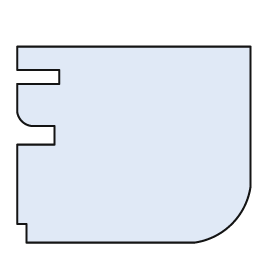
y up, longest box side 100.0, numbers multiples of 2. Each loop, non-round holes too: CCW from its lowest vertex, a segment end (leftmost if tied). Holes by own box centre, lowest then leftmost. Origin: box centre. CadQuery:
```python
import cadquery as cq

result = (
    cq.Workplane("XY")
    .moveTo(-46.0, -42.0)
    .lineTo(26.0, -42.0)
    .threePointArc((42.0, -34.0), (50.0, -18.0))
    .lineTo(50.0, 42.0)
    .lineTo(-50.0, 42.0)
    .lineTo(-50.0, 32.0)
    .lineTo(-32.0, 32.0)
    .lineTo(-32.0, 26.0)
    .lineTo(-50.0, 26.0)
    .lineTo(-50.0, 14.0)
    .threePointArc((-48.0, 10.0), (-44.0, 8.0))
    .lineTo(-34.0, 8.0)
    .lineTo(-34.0, 0.0)
    .lineTo(-50.0, 0.0)
    .lineTo(-50.0, -34.0)
    .lineTo(-46.0, -34.0)
    .close()
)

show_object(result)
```